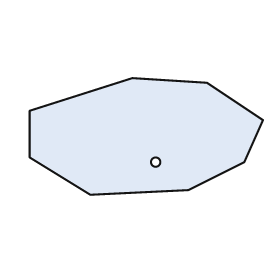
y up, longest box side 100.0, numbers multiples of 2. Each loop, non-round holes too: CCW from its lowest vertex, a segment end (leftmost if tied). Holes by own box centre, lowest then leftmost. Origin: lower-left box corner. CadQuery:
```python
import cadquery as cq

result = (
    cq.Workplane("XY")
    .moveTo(26.0, 0.0)
    .lineTo(68.0, 2.0)
    .lineTo(92.0, 14.0)
    .lineTo(100.0, 32.0)
    .lineTo(76.0, 48.0)
    .lineTo(44.0, 50.0)
    .lineTo(0.0, 36.0)
    .lineTo(0.0, 16.0)
    .close()
    .moveTo(54.0, 14.0)
    .circle(2.0)
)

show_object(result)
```